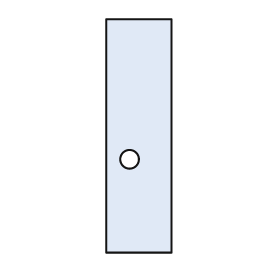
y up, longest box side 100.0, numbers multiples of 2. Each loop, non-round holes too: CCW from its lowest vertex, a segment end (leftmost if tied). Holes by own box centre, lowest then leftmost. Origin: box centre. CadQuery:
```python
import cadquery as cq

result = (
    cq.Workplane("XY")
    .moveTo(-14.0, -50.0)
    .lineTo(14.0, -50.0)
    .lineTo(14.0, 50.0)
    .lineTo(-14.0, 50.0)
    .close()
    .moveTo(-4.0, -10.0)
    .circle(4.0)
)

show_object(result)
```